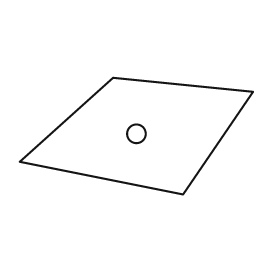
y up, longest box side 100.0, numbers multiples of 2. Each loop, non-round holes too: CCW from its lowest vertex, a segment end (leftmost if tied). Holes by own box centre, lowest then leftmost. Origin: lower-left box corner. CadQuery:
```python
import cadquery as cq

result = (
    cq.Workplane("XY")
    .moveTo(70.0, 0.0)
    .lineTo(100.0, 44.0)
    .lineTo(40.0, 50.0)
    .lineTo(0.0, 14.0)
    .close()
    .moveTo(50.0, 26.0)
    .circle(4.0)
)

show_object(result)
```